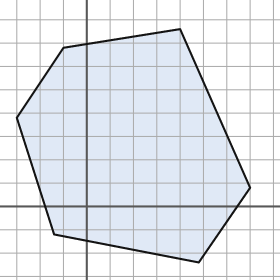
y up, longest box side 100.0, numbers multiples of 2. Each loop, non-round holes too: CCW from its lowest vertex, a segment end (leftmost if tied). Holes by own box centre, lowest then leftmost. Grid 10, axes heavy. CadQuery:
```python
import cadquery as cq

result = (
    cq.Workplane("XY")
    .moveTo(48.0, -24.0)
    .lineTo(70.0, 8.0)
    .lineTo(40.0, 76.0)
    .lineTo(-10.0, 68.0)
    .lineTo(-30.0, 38.0)
    .lineTo(-14.0, -12.0)
    .close()
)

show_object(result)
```